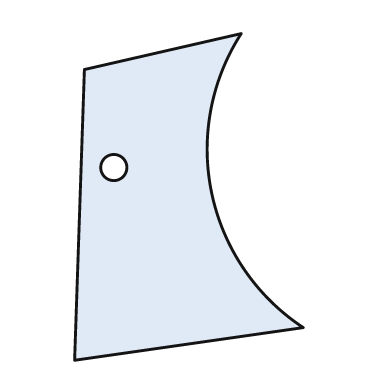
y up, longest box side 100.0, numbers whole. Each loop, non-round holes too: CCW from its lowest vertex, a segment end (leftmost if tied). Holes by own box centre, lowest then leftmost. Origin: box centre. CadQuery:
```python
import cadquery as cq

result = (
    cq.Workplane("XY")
    .moveTo(-35.0, -50.0)
    .lineTo(35.0, -40.0)
    .threePointArc((7.0, 1.0), (16.0, 50.0))
    .lineTo(-32.0, 39.0)
    .close()
    .moveTo(-23.0, 9.0)
    .circle(4.0)
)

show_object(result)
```